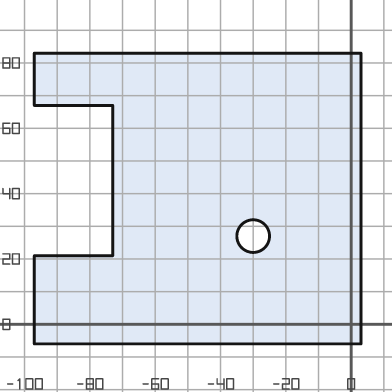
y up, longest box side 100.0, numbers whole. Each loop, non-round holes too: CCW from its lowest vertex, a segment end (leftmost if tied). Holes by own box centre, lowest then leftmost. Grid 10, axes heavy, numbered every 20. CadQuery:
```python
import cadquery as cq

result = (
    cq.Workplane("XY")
    .moveTo(-97.0, -6.0)
    .lineTo(3.0, -6.0)
    .lineTo(3.0, 83.0)
    .lineTo(-97.0, 83.0)
    .lineTo(-97.0, 67.0)
    .lineTo(-73.0, 67.0)
    .lineTo(-73.0, 21.0)
    .lineTo(-97.0, 21.0)
    .close()
    .moveTo(-30.0, 27.0)
    .circle(5.0)
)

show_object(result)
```